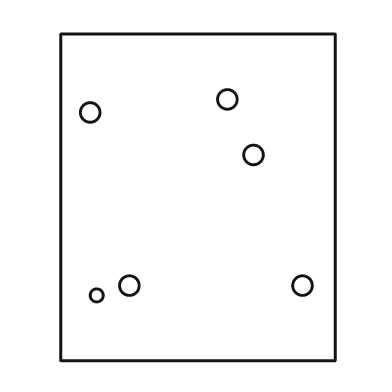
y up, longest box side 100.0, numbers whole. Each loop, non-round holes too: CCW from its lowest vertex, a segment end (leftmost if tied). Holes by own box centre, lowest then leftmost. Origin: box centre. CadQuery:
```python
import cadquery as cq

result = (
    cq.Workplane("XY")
    .moveTo(-42.0, -50.0)
    .lineTo(42.0, -50.0)
    .lineTo(42.0, 50.0)
    .lineTo(-42.0, 50.0)
    .close()
    .moveTo(-31.0, -30.0)
    .circle(2.0)
    .moveTo(-21.0, -27.0)
    .circle(3.0)
    .moveTo(32.0, -27.0)
    .circle(3.0)
    .moveTo(17.0, 13.0)
    .circle(3.0)
    .moveTo(-33.0, 26.0)
    .circle(3.0)
    .moveTo(9.0, 30.0)
    .circle(3.0)
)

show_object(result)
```